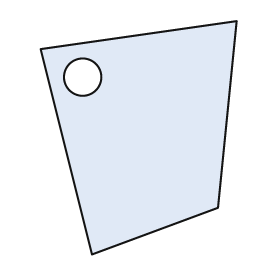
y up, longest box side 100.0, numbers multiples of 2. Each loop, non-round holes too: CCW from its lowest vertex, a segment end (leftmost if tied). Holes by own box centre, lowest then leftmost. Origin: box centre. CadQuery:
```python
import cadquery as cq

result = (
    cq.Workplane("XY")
    .moveTo(-20.0, -50.0)
    .lineTo(34.0, -30.0)
    .lineTo(42.0, 50.0)
    .lineTo(-42.0, 38.0)
    .close()
    .moveTo(-24.0, 26.0)
    .circle(8.0)
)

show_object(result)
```